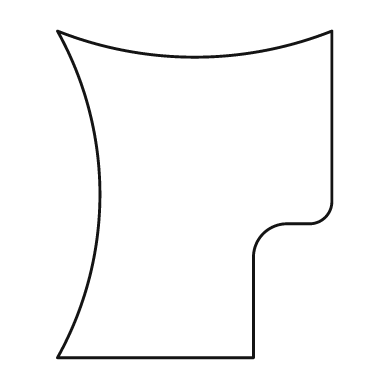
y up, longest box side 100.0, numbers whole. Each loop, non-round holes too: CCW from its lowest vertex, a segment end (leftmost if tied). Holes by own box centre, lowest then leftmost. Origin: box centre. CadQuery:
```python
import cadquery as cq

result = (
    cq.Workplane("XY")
    .moveTo(-42.0, -50.0)
    .lineTo(18.0, -50.0)
    .lineTo(18.0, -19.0)
    .threePointArc((21.0, -12.0), (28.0, -9.0))
    .lineTo(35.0, -9.0)
    .threePointArc((40.0, -7.0), (42.0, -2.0))
    .lineTo(42.0, 50.0)
    .threePointArc((0.0, 42.0), (-42.0, 50.0))
    .threePointArc((-29.0, 0.0), (-42.0, -50.0))
    .close()
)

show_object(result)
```